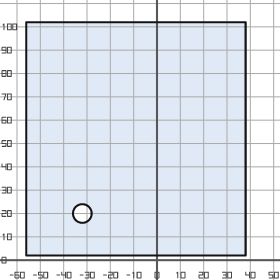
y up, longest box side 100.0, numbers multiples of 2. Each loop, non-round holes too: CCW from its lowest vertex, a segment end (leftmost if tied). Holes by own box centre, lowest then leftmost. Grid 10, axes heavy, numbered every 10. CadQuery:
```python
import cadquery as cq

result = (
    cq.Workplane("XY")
    .moveTo(-56.0, 2.0)
    .lineTo(38.0, 2.0)
    .lineTo(38.0, 102.0)
    .lineTo(-56.0, 102.0)
    .close()
    .moveTo(-32.0, 20.0)
    .circle(4.0)
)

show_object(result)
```